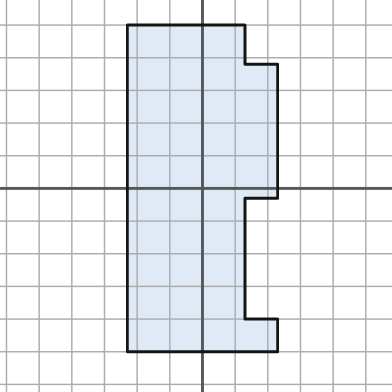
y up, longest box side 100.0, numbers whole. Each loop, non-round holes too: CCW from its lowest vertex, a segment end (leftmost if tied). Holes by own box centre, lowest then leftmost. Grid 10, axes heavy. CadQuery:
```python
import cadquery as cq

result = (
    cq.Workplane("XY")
    .moveTo(-23.0, -50.0)
    .lineTo(23.0, -50.0)
    .lineTo(23.0, -40.0)
    .lineTo(13.0, -40.0)
    .lineTo(13.0, -3.0)
    .lineTo(23.0, -3.0)
    .lineTo(23.0, 38.0)
    .lineTo(13.0, 38.0)
    .lineTo(13.0, 50.0)
    .lineTo(-23.0, 50.0)
    .close()
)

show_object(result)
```